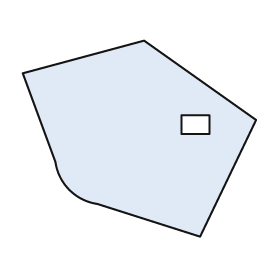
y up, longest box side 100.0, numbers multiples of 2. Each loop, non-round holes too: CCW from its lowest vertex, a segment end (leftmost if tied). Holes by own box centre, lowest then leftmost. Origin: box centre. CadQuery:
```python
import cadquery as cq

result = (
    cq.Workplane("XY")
    .moveTo(26.0, -42.0)
    .lineTo(50.0, 8.0)
    .lineTo(2.0, 42.0)
    .lineTo(-50.0, 28.0)
    .lineTo(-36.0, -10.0)
    .threePointArc((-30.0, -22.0), (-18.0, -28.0))
    .close()
    .moveTo(18.0, 2.0)
    .lineTo(30.0, 2.0)
    .lineTo(30.0, 10.0)
    .lineTo(18.0, 10.0)
    .close()
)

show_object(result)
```